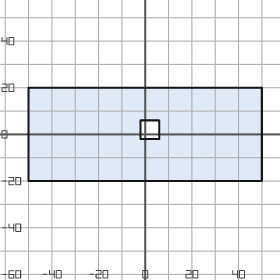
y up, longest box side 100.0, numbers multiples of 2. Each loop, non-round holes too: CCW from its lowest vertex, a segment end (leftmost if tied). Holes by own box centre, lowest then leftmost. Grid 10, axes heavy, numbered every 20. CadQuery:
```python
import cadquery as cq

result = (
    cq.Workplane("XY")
    .moveTo(-50.0, -20.0)
    .lineTo(50.0, -20.0)
    .lineTo(50.0, 20.0)
    .lineTo(-50.0, 20.0)
    .close()
    .moveTo(-2.0, -2.0)
    .lineTo(6.0, -2.0)
    .lineTo(6.0, 6.0)
    .lineTo(-2.0, 6.0)
    .close()
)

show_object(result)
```